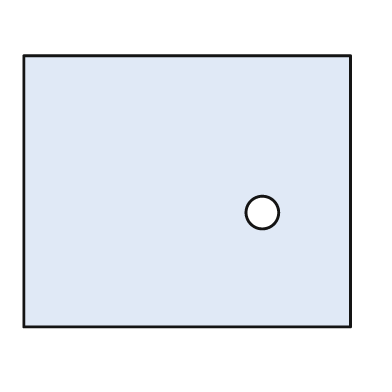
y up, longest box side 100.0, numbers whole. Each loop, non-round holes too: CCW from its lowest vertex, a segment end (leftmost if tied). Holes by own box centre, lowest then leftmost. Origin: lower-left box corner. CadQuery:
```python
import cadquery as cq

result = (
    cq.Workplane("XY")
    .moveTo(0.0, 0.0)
    .lineTo(100.0, 0.0)
    .lineTo(100.0, 83.0)
    .lineTo(0.0, 83.0)
    .close()
    .moveTo(73.0, 35.0)
    .circle(5.0)
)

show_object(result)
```